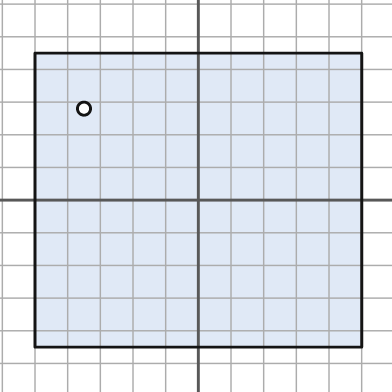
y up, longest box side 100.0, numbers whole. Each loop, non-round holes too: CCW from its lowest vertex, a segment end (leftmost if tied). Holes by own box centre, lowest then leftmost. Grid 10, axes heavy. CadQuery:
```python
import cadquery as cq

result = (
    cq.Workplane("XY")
    .moveTo(-50.0, -45.0)
    .lineTo(50.0, -45.0)
    .lineTo(50.0, 45.0)
    .lineTo(-50.0, 45.0)
    .close()
    .moveTo(-35.0, 28.0)
    .circle(2.0)
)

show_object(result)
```